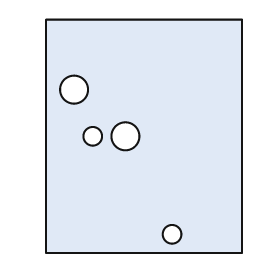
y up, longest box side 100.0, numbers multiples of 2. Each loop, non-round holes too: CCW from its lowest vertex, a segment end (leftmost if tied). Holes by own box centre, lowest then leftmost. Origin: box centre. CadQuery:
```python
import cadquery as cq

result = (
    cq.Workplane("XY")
    .moveTo(-42.0, -50.0)
    .lineTo(42.0, -50.0)
    .lineTo(42.0, 50.0)
    .lineTo(-42.0, 50.0)
    .close()
    .moveTo(12.0, -42.0)
    .circle(4.0)
    .moveTo(-22.0, 0.0)
    .circle(4.0)
    .moveTo(-8.0, 0.0)
    .circle(6.0)
    .moveTo(-30.0, 20.0)
    .circle(6.0)
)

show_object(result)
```